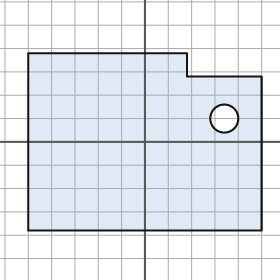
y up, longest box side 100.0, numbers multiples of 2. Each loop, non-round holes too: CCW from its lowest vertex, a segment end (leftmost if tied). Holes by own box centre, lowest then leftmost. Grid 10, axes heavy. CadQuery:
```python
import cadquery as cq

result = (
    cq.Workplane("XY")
    .moveTo(-50.0, -38.0)
    .lineTo(50.0, -38.0)
    .lineTo(50.0, 28.0)
    .lineTo(18.0, 28.0)
    .lineTo(18.0, 38.0)
    .lineTo(-50.0, 38.0)
    .close()
    .moveTo(34.0, 10.0)
    .circle(6.0)
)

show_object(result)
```